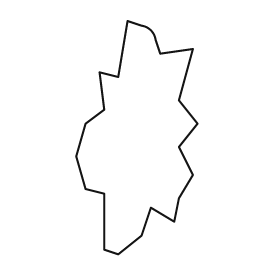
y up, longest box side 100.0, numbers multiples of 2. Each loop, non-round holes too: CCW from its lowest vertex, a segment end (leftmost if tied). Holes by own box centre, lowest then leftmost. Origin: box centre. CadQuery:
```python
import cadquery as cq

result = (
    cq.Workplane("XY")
    .moveTo(-8.0, -50.0)
    .lineTo(2.0, -42.0)
    .lineTo(6.0, -30.0)
    .lineTo(16.0, -36.0)
    .lineTo(18.0, -26.0)
    .lineTo(24.0, -16.0)
    .lineTo(18.0, -4.0)
    .lineTo(26.0, 6.0)
    .lineTo(18.0, 16.0)
    .lineTo(24.0, 38.0)
    .lineTo(10.0, 36.0)
    .lineTo(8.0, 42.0)
    .threePointArc((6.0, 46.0), (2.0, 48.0))
    .lineTo(-4.0, 50.0)
    .lineTo(-8.0, 26.0)
    .lineTo(-16.0, 28.0)
    .lineTo(-14.0, 12.0)
    .lineTo(-22.0, 6.0)
    .lineTo(-26.0, -8.0)
    .lineTo(-22.0, -22.0)
    .lineTo(-14.0, -24.0)
    .lineTo(-14.0, -48.0)
    .close()
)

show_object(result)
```